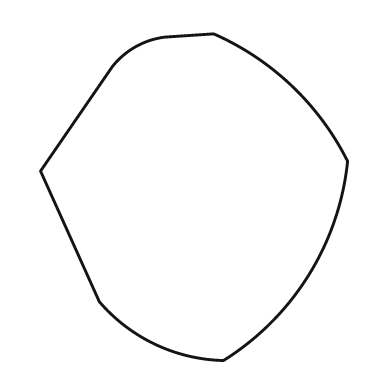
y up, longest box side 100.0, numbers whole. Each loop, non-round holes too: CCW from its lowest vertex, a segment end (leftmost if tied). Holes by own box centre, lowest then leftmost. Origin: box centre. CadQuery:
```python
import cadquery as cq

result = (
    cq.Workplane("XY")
    .moveTo(9.0, -50.0)
    .threePointArc((35.0, -24.0), (47.0, 11.0))
    .threePointArc((30.0, 34.0), (6.0, 50.0))
    .lineTo(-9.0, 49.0)
    .threePointArc((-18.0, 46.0), (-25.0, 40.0))
    .lineTo(-47.0, 8.0)
    .lineTo(-29.0, -32.0)
    .threePointArc((-12.0, -45.0), (9.0, -50.0))
    .close()
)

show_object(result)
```